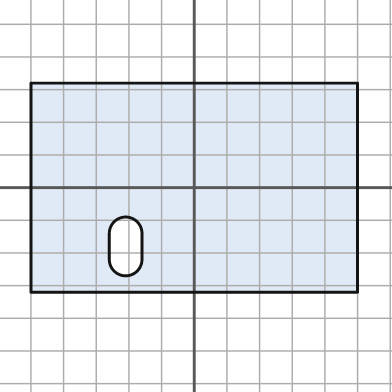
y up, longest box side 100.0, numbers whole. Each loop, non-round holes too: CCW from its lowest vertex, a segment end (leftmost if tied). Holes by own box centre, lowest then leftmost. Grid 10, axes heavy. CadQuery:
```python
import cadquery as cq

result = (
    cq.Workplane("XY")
    .moveTo(-50.0, -32.0)
    .lineTo(50.0, -32.0)
    .lineTo(50.0, 32.0)
    .lineTo(-50.0, 32.0)
    .close()
    .moveTo(-26.0, -22.0)
    .threePointArc((-21.0, -27.0), (-16.0, -22.0))
    .lineTo(-16.0, -14.0)
    .threePointArc((-21.0, -9.0), (-26.0, -14.0))
    .close()
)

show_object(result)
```